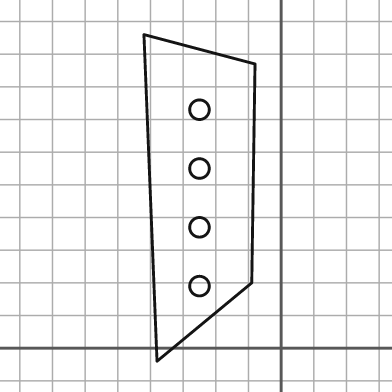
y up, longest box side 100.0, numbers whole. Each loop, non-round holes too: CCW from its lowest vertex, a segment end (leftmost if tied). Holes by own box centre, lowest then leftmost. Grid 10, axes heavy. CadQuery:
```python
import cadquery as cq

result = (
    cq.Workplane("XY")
    .moveTo(-38.0, -4.0)
    .lineTo(-9.0, 20.0)
    .lineTo(-8.0, 87.0)
    .lineTo(-42.0, 96.0)
    .close()
    .moveTo(-25.0, 19.0)
    .circle(3.0)
    .moveTo(-25.0, 37.0)
    .circle(3.0)
    .moveTo(-25.0, 55.0)
    .circle(3.0)
    .moveTo(-25.0, 73.0)
    .circle(3.0)
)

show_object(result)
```